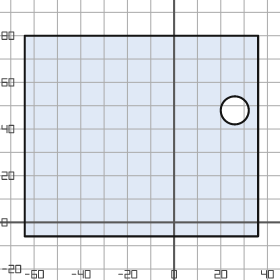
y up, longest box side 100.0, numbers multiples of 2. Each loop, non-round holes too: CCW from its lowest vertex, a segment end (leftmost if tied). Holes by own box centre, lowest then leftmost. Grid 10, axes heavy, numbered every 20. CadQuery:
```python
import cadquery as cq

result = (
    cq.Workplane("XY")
    .moveTo(-64.0, -6.0)
    .lineTo(36.0, -6.0)
    .lineTo(36.0, 80.0)
    .lineTo(-64.0, 80.0)
    .close()
    .moveTo(26.0, 48.0)
    .circle(6.0)
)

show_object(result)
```